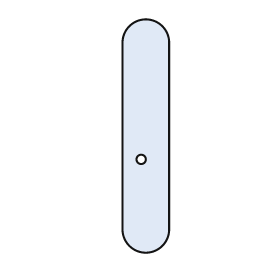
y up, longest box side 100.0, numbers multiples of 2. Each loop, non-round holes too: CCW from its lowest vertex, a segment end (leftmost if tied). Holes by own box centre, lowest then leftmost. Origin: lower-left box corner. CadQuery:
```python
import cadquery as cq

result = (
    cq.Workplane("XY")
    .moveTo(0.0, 10.0)
    .threePointArc((10.0, 0.0), (20.0, 10.0))
    .lineTo(20.0, 90.0)
    .threePointArc((10.0, 100.0), (0.0, 90.0))
    .close()
    .moveTo(8.0, 40.0)
    .circle(2.0)
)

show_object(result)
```